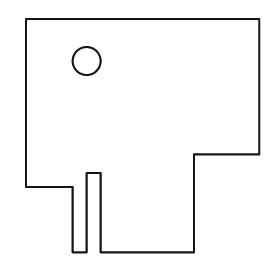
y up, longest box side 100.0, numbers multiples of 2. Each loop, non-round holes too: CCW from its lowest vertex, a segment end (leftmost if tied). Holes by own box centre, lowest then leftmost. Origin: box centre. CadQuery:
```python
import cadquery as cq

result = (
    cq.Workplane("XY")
    .moveTo(-30.0, -50.0)
    .lineTo(-24.0, -50.0)
    .lineTo(-24.0, -16.0)
    .lineTo(-18.0, -16.0)
    .lineTo(-18.0, -50.0)
    .lineTo(22.0, -50.0)
    .lineTo(22.0, -8.0)
    .lineTo(50.0, -8.0)
    .lineTo(50.0, 50.0)
    .lineTo(-50.0, 50.0)
    .lineTo(-50.0, -22.0)
    .lineTo(-30.0, -22.0)
    .close()
    .moveTo(-24.0, 32.0)
    .circle(6.0)
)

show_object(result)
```